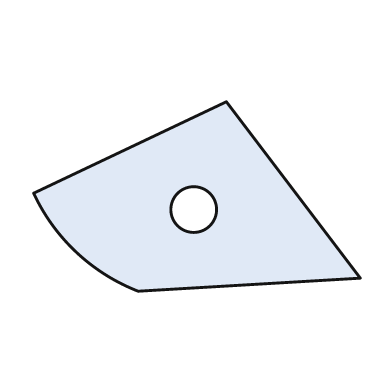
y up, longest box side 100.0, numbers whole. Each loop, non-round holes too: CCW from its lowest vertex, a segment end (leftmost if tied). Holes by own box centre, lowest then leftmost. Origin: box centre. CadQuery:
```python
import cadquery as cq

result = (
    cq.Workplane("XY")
    .moveTo(-18.0, -29.0)
    .lineTo(50.0, -25.0)
    .lineTo(9.0, 29.0)
    .lineTo(-50.0, 1.0)
    .threePointArc((-37.0, -17.0), (-18.0, -29.0))
    .close()
    .moveTo(-1.0, -4.0)
    .circle(7.0)
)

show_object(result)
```